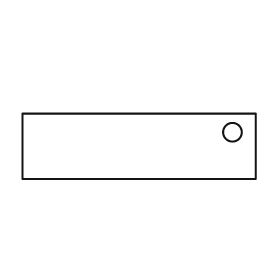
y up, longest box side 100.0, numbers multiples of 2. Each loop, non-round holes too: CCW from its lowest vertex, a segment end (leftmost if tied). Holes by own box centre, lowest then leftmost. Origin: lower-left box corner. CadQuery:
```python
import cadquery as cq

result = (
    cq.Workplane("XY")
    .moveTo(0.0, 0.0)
    .lineTo(100.0, 0.0)
    .lineTo(100.0, 28.0)
    .lineTo(0.0, 28.0)
    .close()
    .moveTo(90.0, 20.0)
    .circle(4.0)
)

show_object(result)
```